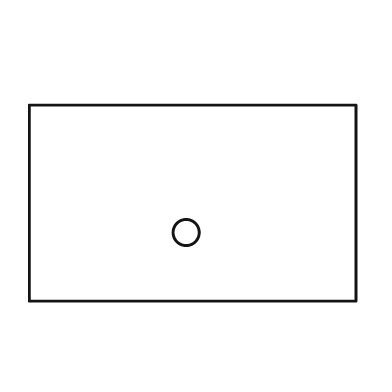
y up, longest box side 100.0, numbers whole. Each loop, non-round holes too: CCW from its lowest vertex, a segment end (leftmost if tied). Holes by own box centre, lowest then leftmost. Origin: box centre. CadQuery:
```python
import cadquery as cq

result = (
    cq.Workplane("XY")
    .moveTo(-50.0, -30.0)
    .lineTo(50.0, -30.0)
    .lineTo(50.0, 30.0)
    .lineTo(-50.0, 30.0)
    .close()
    .moveTo(-2.0, -9.0)
    .circle(4.0)
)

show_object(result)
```